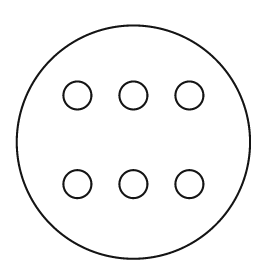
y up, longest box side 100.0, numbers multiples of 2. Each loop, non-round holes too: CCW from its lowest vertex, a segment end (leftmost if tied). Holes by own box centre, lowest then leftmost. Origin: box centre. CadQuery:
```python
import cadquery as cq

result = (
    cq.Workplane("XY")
    .moveTo(0.0, 0.0)
    .circle(50.0)
    .moveTo(-24.0, -18.0)
    .circle(6.0)
    .moveTo(0.0, -18.0)
    .circle(6.0)
    .moveTo(24.0, -18.0)
    .circle(6.0)
    .moveTo(-24.0, 20.0)
    .circle(6.0)
    .moveTo(0.0, 20.0)
    .circle(6.0)
    .moveTo(24.0, 20.0)
    .circle(6.0)
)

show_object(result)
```